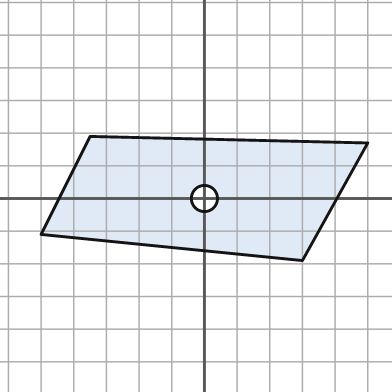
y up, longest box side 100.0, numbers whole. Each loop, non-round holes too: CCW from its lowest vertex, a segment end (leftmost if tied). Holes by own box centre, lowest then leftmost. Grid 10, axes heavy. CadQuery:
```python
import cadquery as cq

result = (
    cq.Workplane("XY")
    .moveTo(30.0, -19.0)
    .lineTo(50.0, 17.0)
    .lineTo(-35.0, 19.0)
    .lineTo(-50.0, -11.0)
    .close()
    .moveTo(0.0, 0.0)
    .circle(4.0)
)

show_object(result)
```